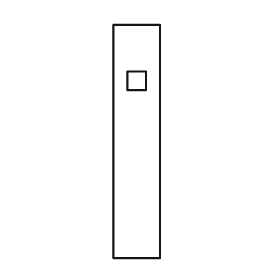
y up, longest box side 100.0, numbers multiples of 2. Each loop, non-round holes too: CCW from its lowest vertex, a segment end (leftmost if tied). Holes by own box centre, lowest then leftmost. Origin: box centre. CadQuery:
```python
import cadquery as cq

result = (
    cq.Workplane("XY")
    .moveTo(-10.0, -50.0)
    .lineTo(10.0, -50.0)
    .lineTo(10.0, 50.0)
    .lineTo(-10.0, 50.0)
    .close()
    .moveTo(-4.0, 22.0)
    .lineTo(4.0, 22.0)
    .lineTo(4.0, 30.0)
    .lineTo(-4.0, 30.0)
    .close()
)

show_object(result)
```